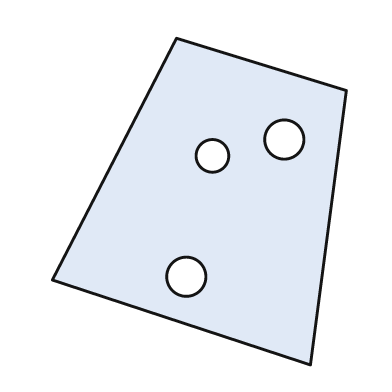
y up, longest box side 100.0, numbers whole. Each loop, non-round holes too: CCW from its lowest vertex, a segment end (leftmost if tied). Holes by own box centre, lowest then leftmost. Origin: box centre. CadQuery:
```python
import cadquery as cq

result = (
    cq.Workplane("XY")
    .moveTo(34.0, -50.0)
    .lineTo(45.0, 34.0)
    .lineTo(-7.0, 50.0)
    .lineTo(-45.0, -24.0)
    .close()
    .moveTo(-4.0, -23.0)
    .circle(6.0)
    .moveTo(4.0, 14.0)
    .circle(5.0)
    .moveTo(26.0, 19.0)
    .circle(6.0)
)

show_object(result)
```